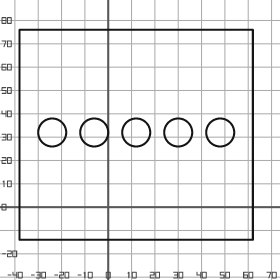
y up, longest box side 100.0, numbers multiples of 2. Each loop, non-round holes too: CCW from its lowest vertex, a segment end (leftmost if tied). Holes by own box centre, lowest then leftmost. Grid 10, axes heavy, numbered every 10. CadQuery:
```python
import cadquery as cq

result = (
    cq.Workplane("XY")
    .moveTo(-38.0, -14.0)
    .lineTo(62.0, -14.0)
    .lineTo(62.0, 76.0)
    .lineTo(-38.0, 76.0)
    .close()
    .moveTo(-24.0, 32.0)
    .circle(6.0)
    .moveTo(-6.0, 32.0)
    .circle(6.0)
    .moveTo(12.0, 32.0)
    .circle(6.0)
    .moveTo(30.0, 32.0)
    .circle(6.0)
    .moveTo(48.0, 32.0)
    .circle(6.0)
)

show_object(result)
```